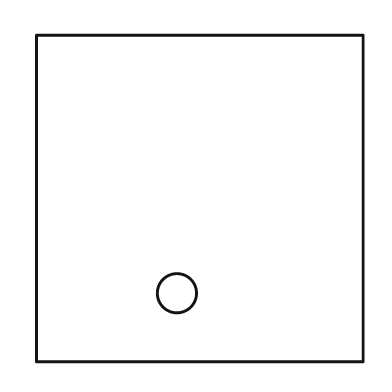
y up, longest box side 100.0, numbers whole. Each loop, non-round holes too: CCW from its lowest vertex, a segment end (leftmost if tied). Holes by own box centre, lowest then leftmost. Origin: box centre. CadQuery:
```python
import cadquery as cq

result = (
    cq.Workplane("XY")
    .moveTo(-50.0, -50.0)
    .lineTo(50.0, -50.0)
    .lineTo(50.0, 50.0)
    .lineTo(-50.0, 50.0)
    .close()
    .moveTo(-7.0, -29.0)
    .circle(6.0)
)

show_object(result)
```